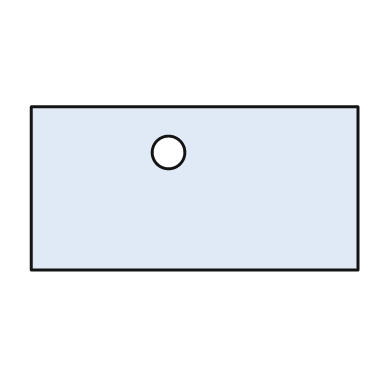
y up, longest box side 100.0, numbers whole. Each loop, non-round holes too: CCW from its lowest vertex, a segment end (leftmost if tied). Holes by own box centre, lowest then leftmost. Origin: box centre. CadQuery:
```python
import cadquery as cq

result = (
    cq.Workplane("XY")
    .moveTo(-50.0, -25.0)
    .lineTo(50.0, -25.0)
    .lineTo(50.0, 25.0)
    .lineTo(-50.0, 25.0)
    .close()
    .moveTo(-8.0, 11.0)
    .circle(5.0)
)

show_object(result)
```